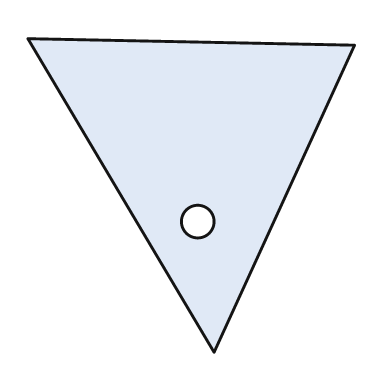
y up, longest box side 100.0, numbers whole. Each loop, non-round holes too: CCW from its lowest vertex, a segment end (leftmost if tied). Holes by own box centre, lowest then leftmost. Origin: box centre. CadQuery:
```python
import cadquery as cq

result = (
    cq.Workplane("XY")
    .moveTo(7.0, -48.0)
    .lineTo(50.0, 46.0)
    .lineTo(-50.0, 48.0)
    .close()
    .moveTo(2.0, -8.0)
    .circle(5.0)
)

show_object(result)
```